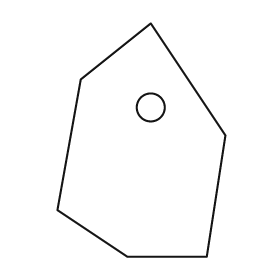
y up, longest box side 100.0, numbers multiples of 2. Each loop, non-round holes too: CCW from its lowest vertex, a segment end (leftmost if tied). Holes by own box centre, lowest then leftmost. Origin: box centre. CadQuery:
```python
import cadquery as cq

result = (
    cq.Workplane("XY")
    .moveTo(-6.0, -50.0)
    .lineTo(28.0, -50.0)
    .lineTo(36.0, 2.0)
    .lineTo(4.0, 50.0)
    .lineTo(-26.0, 26.0)
    .lineTo(-36.0, -30.0)
    .close()
    .moveTo(4.0, 14.0)
    .circle(6.0)
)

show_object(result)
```